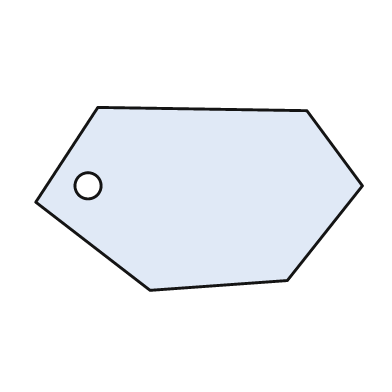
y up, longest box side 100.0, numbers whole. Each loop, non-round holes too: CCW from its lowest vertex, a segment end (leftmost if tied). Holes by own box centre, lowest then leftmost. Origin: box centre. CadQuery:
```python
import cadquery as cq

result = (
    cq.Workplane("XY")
    .moveTo(-15.0, -28.0)
    .lineTo(27.0, -25.0)
    .lineTo(50.0, 4.0)
    .lineTo(33.0, 27.0)
    .lineTo(-31.0, 28.0)
    .lineTo(-50.0, -1.0)
    .close()
    .moveTo(-34.0, 4.0)
    .circle(4.0)
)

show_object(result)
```